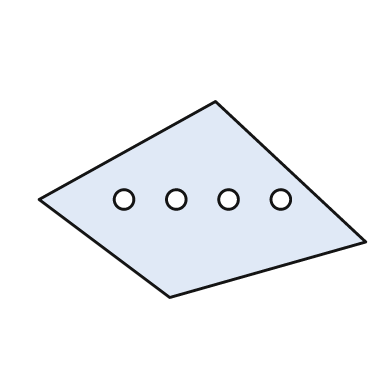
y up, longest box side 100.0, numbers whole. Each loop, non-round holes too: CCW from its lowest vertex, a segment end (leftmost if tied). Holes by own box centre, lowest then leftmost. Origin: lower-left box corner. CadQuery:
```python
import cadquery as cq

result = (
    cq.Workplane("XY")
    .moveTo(40.0, 0.0)
    .lineTo(100.0, 17.0)
    .lineTo(54.0, 60.0)
    .lineTo(0.0, 30.0)
    .close()
    .moveTo(26.0, 30.0)
    .circle(3.0)
    .moveTo(42.0, 30.0)
    .circle(3.0)
    .moveTo(58.0, 30.0)
    .circle(3.0)
    .moveTo(74.0, 30.0)
    .circle(3.0)
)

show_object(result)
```